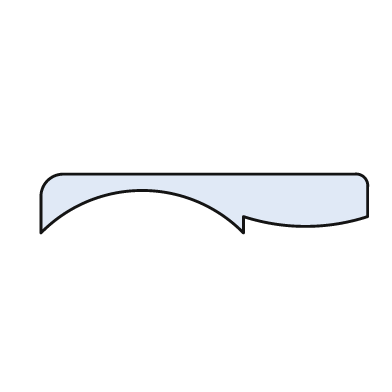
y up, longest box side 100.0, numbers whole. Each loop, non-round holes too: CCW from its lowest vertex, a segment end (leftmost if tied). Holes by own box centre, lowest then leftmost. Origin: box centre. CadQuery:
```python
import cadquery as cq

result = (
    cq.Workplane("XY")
    .moveTo(-50.0, -9.0)
    .threePointArc((-19.0, 4.0), (12.0, -9.0))
    .lineTo(12.0, -4.0)
    .threePointArc((31.0, -7.0), (50.0, -4.0))
    .lineTo(50.0, 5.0)
    .threePointArc((49.0, 8.0), (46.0, 9.0))
    .lineTo(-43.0, 9.0)
    .threePointArc((-48.0, 7.0), (-50.0, 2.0))
    .close()
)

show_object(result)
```